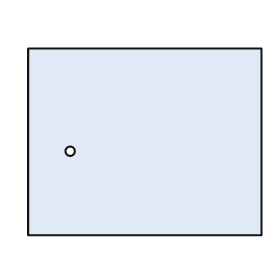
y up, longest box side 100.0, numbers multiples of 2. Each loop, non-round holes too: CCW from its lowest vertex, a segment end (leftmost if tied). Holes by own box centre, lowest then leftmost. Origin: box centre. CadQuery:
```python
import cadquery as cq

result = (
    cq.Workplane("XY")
    .moveTo(-50.0, -40.0)
    .lineTo(50.0, -40.0)
    .lineTo(50.0, 40.0)
    .lineTo(-50.0, 40.0)
    .close()
    .moveTo(-32.0, -4.0)
    .circle(2.0)
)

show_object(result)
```